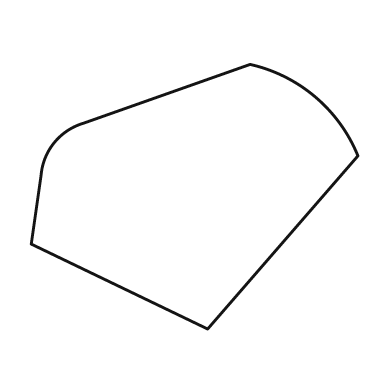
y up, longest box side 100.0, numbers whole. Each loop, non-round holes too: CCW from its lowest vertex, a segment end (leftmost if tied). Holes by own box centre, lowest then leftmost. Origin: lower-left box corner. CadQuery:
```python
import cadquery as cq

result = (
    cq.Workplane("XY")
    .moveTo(54.0, 0.0)
    .lineTo(100.0, 53.0)
    .threePointArc((87.0, 71.0), (67.0, 81.0))
    .lineTo(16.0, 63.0)
    .threePointArc((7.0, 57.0), (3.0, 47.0))
    .lineTo(0.0, 26.0)
    .close()
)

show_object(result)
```